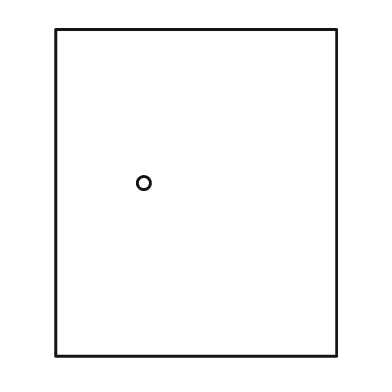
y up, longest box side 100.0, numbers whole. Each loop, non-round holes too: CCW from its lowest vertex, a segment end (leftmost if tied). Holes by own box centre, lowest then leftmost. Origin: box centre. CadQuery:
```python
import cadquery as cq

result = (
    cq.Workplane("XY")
    .moveTo(-43.0, -50.0)
    .lineTo(43.0, -50.0)
    .lineTo(43.0, 50.0)
    .lineTo(-43.0, 50.0)
    .close()
    .moveTo(-16.0, 3.0)
    .circle(2.0)
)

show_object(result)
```